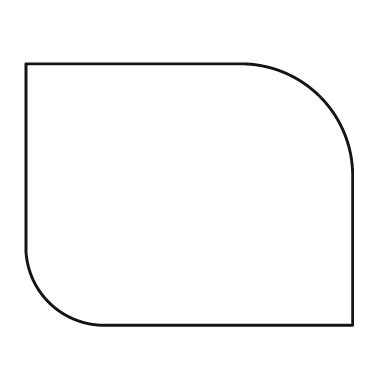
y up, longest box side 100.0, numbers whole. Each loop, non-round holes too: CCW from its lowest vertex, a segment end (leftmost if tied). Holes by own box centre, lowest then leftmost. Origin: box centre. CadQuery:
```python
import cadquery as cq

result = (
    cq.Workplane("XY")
    .moveTo(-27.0, -40.0)
    .lineTo(50.0, -40.0)
    .lineTo(50.0, 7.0)
    .threePointArc((40.0, 30.0), (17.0, 40.0))
    .lineTo(-50.0, 40.0)
    .lineTo(-50.0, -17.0)
    .threePointArc((-43.0, -33.0), (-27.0, -40.0))
    .close()
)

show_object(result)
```